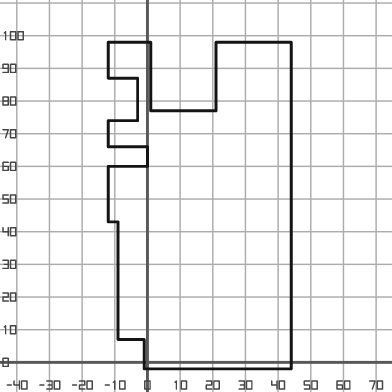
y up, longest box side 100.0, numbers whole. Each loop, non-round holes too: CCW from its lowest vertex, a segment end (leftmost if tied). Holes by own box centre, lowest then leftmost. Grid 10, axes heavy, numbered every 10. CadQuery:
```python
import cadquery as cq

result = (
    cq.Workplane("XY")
    .moveTo(-1.0, -2.0)
    .lineTo(44.0, -2.0)
    .lineTo(44.0, 98.0)
    .lineTo(21.0, 98.0)
    .lineTo(21.0, 77.0)
    .lineTo(1.0, 77.0)
    .lineTo(1.0, 98.0)
    .lineTo(-12.0, 98.0)
    .lineTo(-12.0, 87.0)
    .lineTo(-3.0, 87.0)
    .lineTo(-3.0, 74.0)
    .lineTo(-12.0, 74.0)
    .lineTo(-12.0, 66.0)
    .lineTo(0.0, 66.0)
    .lineTo(0.0, 60.0)
    .lineTo(-12.0, 60.0)
    .lineTo(-12.0, 43.0)
    .lineTo(-9.0, 43.0)
    .lineTo(-9.0, 7.0)
    .lineTo(-1.0, 7.0)
    .close()
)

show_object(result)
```